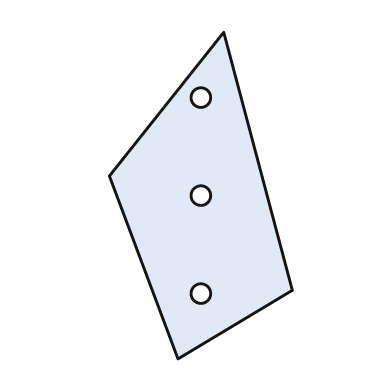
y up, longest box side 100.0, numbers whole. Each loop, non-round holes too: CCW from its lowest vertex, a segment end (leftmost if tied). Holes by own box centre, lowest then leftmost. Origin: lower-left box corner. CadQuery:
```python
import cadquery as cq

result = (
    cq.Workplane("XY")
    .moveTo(21.0, 0.0)
    .lineTo(56.0, 21.0)
    .lineTo(35.0, 100.0)
    .lineTo(0.0, 56.0)
    .close()
    .moveTo(28.0, 20.0)
    .circle(3.0)
    .moveTo(28.0, 50.0)
    .circle(3.0)
    .moveTo(28.0, 80.0)
    .circle(3.0)
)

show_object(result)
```